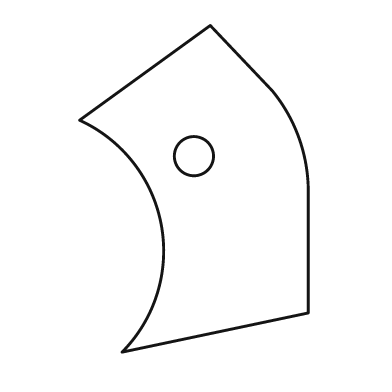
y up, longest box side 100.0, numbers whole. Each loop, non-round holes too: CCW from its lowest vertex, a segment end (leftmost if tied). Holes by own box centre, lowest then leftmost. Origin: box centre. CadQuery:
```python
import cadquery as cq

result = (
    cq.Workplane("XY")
    .moveTo(-22.0, -50.0)
    .lineTo(35.0, -38.0)
    .lineTo(35.0, 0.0)
    .threePointArc((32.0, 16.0), (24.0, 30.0))
    .lineTo(5.0, 50.0)
    .lineTo(-35.0, 21.0)
    .threePointArc((-10.0, -11.0), (-22.0, -50.0))
    .close()
    .moveTo(0.0, 10.0)
    .circle(6.0)
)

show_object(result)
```